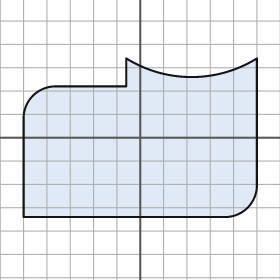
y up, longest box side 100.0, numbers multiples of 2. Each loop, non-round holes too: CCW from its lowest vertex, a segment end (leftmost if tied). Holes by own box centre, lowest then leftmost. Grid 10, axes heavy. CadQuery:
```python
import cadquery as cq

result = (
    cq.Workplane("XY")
    .moveTo(-50.0, -34.0)
    .lineTo(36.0, -34.0)
    .threePointArc((46.0, -30.0), (50.0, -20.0))
    .lineTo(50.0, 34.0)
    .threePointArc((22.0, 26.0), (-6.0, 34.0))
    .lineTo(-6.0, 22.0)
    .lineTo(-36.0, 22.0)
    .threePointArc((-46.0, 18.0), (-50.0, 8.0))
    .close()
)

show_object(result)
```